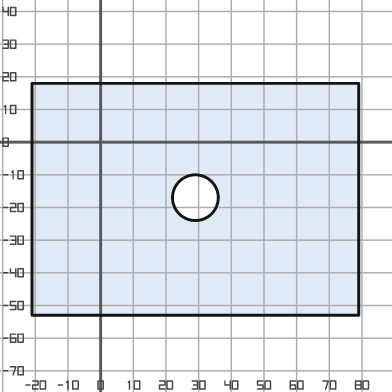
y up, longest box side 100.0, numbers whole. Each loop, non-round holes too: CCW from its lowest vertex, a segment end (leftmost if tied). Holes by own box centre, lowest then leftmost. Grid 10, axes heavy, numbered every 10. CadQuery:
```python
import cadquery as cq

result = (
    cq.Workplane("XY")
    .moveTo(-21.0, -53.0)
    .lineTo(79.0, -53.0)
    .lineTo(79.0, 18.0)
    .lineTo(-21.0, 18.0)
    .close()
    .moveTo(29.0, -17.0)
    .circle(7.0)
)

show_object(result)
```